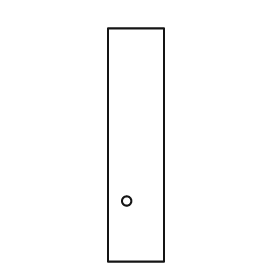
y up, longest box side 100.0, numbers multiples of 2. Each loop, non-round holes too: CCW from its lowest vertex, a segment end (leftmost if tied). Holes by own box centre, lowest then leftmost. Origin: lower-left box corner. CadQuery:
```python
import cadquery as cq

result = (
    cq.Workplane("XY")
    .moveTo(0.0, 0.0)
    .lineTo(24.0, 0.0)
    .lineTo(24.0, 100.0)
    .lineTo(0.0, 100.0)
    .close()
    .moveTo(8.0, 26.0)
    .circle(2.0)
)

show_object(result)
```